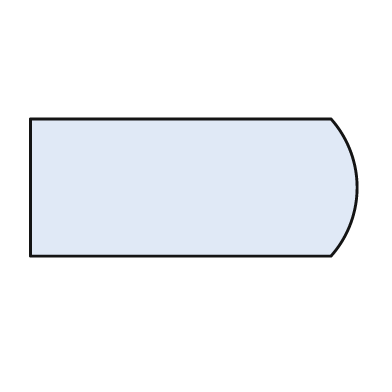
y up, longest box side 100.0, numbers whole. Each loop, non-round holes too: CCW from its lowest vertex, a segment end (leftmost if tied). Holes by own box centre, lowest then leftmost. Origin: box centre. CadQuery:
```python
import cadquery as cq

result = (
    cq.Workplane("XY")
    .moveTo(-50.0, -21.0)
    .lineTo(42.0, -21.0)
    .threePointArc((50.0, 0.0), (42.0, 21.0))
    .lineTo(-50.0, 21.0)
    .close()
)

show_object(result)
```